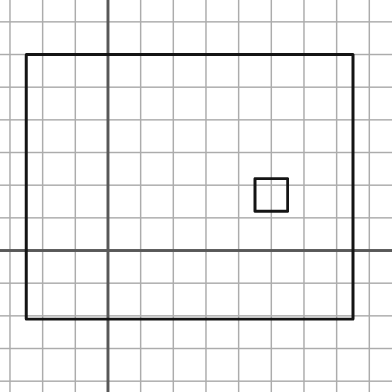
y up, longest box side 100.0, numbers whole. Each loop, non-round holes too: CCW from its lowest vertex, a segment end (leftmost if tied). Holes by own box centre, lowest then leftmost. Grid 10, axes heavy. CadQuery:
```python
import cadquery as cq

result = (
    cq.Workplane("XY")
    .moveTo(-25.0, -21.0)
    .lineTo(75.0, -21.0)
    .lineTo(75.0, 60.0)
    .lineTo(-25.0, 60.0)
    .close()
    .moveTo(45.0, 12.0)
    .lineTo(55.0, 12.0)
    .lineTo(55.0, 22.0)
    .lineTo(45.0, 22.0)
    .close()
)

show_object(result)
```